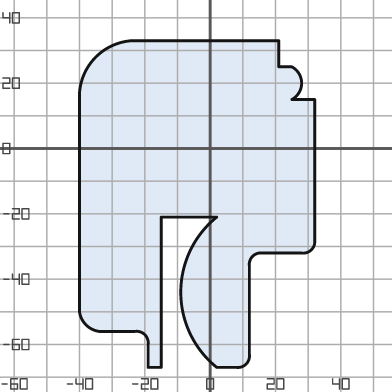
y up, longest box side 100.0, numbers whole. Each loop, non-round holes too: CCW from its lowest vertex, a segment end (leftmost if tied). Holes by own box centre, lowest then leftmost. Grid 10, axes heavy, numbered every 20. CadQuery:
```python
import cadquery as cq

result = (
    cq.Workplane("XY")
    .moveTo(-19.0, -67.0)
    .lineTo(-15.0, -67.0)
    .lineTo(-15.0, -21.0)
    .lineTo(2.0, -21.0)
    .threePointArc((-9.0, -44.0), (2.0, -67.0))
    .lineTo(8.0, -67.0)
    .threePointArc((11.0, -66.0), (12.0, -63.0))
    .lineTo(12.0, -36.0)
    .threePointArc((13.0, -33.0), (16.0, -32.0))
    .lineTo(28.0, -32.0)
    .threePointArc((31.0, -31.0), (32.0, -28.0))
    .lineTo(32.0, 15.0)
    .lineTo(25.0, 15.0)
    .threePointArc((28.0, 20.0), (25.0, 25.0))
    .lineTo(21.0, 25.0)
    .lineTo(21.0, 33.0)
    .lineTo(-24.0, 33.0)
    .threePointArc((-35.0, 28.0), (-40.0, 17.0))
    .lineTo(-40.0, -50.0)
    .threePointArc((-38.0, -54.0), (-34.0, -56.0))
    .lineTo(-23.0, -56.0)
    .threePointArc((-20.0, -57.0), (-19.0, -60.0))
    .close()
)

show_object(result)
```